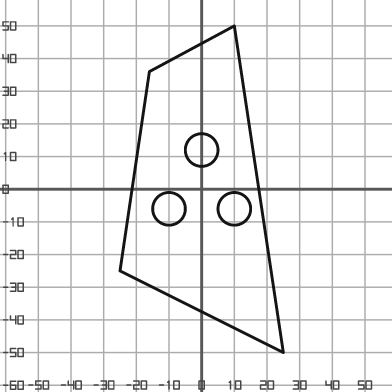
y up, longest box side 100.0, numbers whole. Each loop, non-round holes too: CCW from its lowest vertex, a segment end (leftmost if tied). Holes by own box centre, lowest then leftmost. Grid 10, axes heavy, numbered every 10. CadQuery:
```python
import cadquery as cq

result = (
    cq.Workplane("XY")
    .moveTo(25.0, -50.0)
    .lineTo(10.0, 50.0)
    .lineTo(-16.0, 36.0)
    .lineTo(-25.0, -25.0)
    .close()
    .moveTo(-10.0, -6.0)
    .circle(5.0)
    .moveTo(10.0, -6.0)
    .circle(5.0)
    .moveTo(0.0, 12.0)
    .circle(5.0)
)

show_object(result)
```